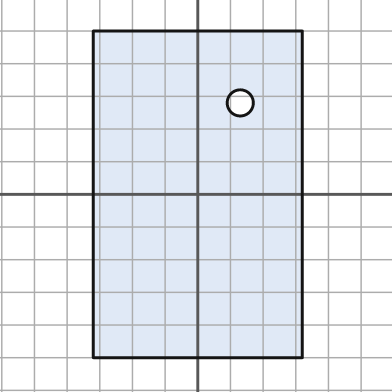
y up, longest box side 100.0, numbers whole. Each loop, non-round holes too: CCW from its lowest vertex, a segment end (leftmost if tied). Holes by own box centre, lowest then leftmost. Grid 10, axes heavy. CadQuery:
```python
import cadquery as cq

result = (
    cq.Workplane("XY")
    .moveTo(-32.0, -50.0)
    .lineTo(32.0, -50.0)
    .lineTo(32.0, 50.0)
    .lineTo(-32.0, 50.0)
    .close()
    .moveTo(13.0, 28.0)
    .circle(4.0)
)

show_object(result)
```